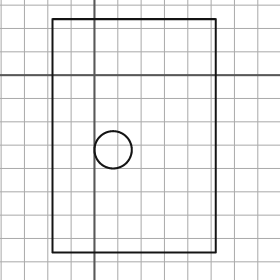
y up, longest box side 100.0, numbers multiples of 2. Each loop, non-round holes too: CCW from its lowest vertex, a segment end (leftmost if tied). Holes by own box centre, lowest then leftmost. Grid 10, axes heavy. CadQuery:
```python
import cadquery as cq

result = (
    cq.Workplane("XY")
    .moveTo(-18.0, -76.0)
    .lineTo(52.0, -76.0)
    .lineTo(52.0, 24.0)
    .lineTo(-18.0, 24.0)
    .close()
    .moveTo(8.0, -32.0)
    .circle(8.0)
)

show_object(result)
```